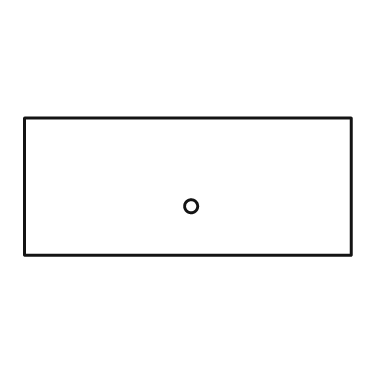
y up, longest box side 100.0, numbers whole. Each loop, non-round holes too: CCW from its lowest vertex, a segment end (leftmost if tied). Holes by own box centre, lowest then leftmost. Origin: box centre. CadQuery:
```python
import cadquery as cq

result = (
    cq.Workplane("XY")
    .moveTo(-50.0, -21.0)
    .lineTo(50.0, -21.0)
    .lineTo(50.0, 21.0)
    .lineTo(-50.0, 21.0)
    .close()
    .moveTo(1.0, -6.0)
    .circle(2.0)
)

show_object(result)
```